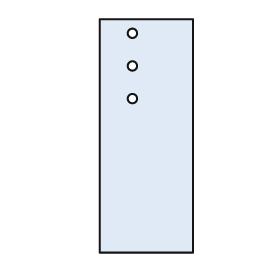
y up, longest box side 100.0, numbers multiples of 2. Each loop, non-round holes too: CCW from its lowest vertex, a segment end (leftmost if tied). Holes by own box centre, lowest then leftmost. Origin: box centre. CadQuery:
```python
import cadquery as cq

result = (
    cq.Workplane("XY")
    .moveTo(-20.0, -50.0)
    .lineTo(20.0, -50.0)
    .lineTo(20.0, 50.0)
    .lineTo(-20.0, 50.0)
    .close()
    .moveTo(-6.0, 16.0)
    .circle(2.0)
    .moveTo(-6.0, 30.0)
    .circle(2.0)
    .moveTo(-6.0, 44.0)
    .circle(2.0)
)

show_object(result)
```